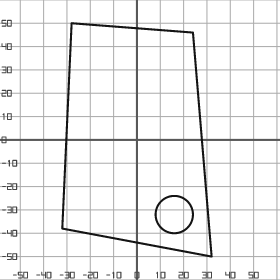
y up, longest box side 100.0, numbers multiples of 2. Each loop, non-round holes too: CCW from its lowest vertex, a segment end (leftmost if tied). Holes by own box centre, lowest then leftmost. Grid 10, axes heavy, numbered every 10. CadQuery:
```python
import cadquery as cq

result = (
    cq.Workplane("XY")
    .moveTo(32.0, -50.0)
    .lineTo(24.0, 46.0)
    .lineTo(-28.0, 50.0)
    .lineTo(-32.0, -38.0)
    .close()
    .moveTo(16.0, -32.0)
    .circle(8.0)
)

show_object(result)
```